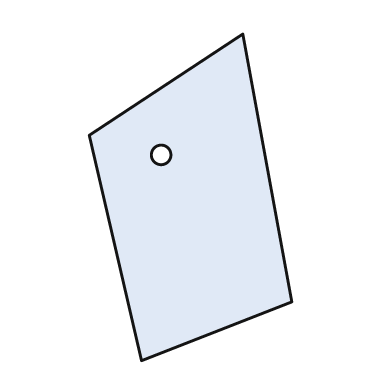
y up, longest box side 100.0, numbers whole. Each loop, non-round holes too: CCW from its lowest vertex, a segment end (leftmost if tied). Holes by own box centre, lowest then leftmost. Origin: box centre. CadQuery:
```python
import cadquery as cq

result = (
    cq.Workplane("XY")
    .moveTo(-15.0, -50.0)
    .lineTo(31.0, -32.0)
    .lineTo(16.0, 50.0)
    .lineTo(-31.0, 19.0)
    .close()
    .moveTo(-9.0, 13.0)
    .circle(3.0)
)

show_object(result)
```